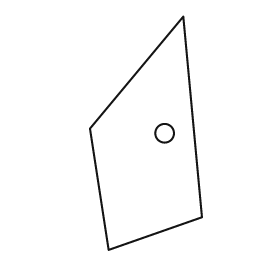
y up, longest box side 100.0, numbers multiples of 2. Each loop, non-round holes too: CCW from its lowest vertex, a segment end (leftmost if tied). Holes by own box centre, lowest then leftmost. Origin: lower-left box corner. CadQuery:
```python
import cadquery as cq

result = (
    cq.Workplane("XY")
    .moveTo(8.0, 0.0)
    .lineTo(48.0, 14.0)
    .lineTo(40.0, 100.0)
    .lineTo(0.0, 52.0)
    .close()
    .moveTo(32.0, 50.0)
    .circle(4.0)
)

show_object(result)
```